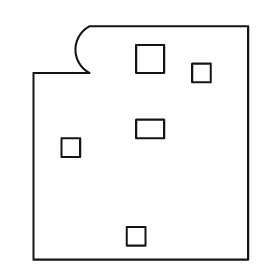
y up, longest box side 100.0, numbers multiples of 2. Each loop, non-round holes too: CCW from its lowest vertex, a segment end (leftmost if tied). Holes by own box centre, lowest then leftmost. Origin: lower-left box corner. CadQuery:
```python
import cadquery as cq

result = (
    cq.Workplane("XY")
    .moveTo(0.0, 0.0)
    .lineTo(92.0, 0.0)
    .lineTo(92.0, 100.0)
    .lineTo(24.0, 100.0)
    .threePointArc((18.0, 90.0), (24.0, 80.0))
    .lineTo(0.0, 80.0)
    .close()
    .moveTo(40.0, 6.0)
    .lineTo(48.0, 6.0)
    .lineTo(48.0, 14.0)
    .lineTo(40.0, 14.0)
    .close()
    .moveTo(12.0, 44.0)
    .lineTo(20.0, 44.0)
    .lineTo(20.0, 52.0)
    .lineTo(12.0, 52.0)
    .close()
    .moveTo(44.0, 52.0)
    .lineTo(56.0, 52.0)
    .lineTo(56.0, 60.0)
    .lineTo(44.0, 60.0)
    .close()
    .moveTo(68.0, 76.0)
    .lineTo(76.0, 76.0)
    .lineTo(76.0, 84.0)
    .lineTo(68.0, 84.0)
    .close()
    .moveTo(44.0, 80.0)
    .lineTo(56.0, 80.0)
    .lineTo(56.0, 92.0)
    .lineTo(44.0, 92.0)
    .close()
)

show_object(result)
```